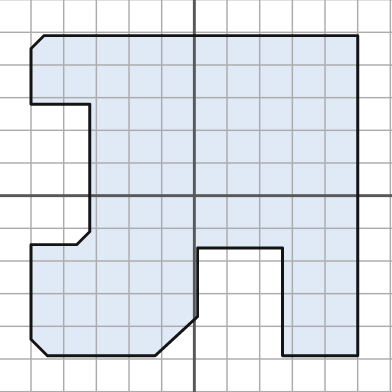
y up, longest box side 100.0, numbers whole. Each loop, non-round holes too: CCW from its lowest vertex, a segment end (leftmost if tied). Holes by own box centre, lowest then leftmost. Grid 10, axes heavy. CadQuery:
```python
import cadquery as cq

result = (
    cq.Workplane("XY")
    .moveTo(-45.0, -49.0)
    .lineTo(-12.0, -49.0)
    .lineTo(1.0, -37.0)
    .lineTo(1.0, -16.0)
    .lineTo(27.0, -16.0)
    .lineTo(27.0, -49.0)
    .lineTo(50.0, -49.0)
    .lineTo(50.0, 49.0)
    .lineTo(-46.0, 49.0)
    .lineTo(-50.0, 45.0)
    .lineTo(-50.0, 28.0)
    .lineTo(-32.0, 28.0)
    .lineTo(-32.0, -11.0)
    .lineTo(-36.0, -15.0)
    .lineTo(-50.0, -15.0)
    .lineTo(-50.0, -44.0)
    .close()
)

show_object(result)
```